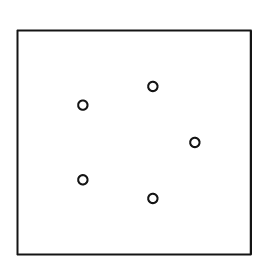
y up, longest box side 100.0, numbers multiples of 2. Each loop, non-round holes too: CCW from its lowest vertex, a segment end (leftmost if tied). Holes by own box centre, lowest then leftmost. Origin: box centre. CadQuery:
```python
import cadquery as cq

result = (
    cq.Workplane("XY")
    .moveTo(-50.0, -48.0)
    .lineTo(50.0, -48.0)
    .lineTo(50.0, 48.0)
    .lineTo(-50.0, 48.0)
    .close()
    .moveTo(8.0, -24.0)
    .circle(2.0)
    .moveTo(-22.0, -16.0)
    .circle(2.0)
    .moveTo(26.0, 0.0)
    .circle(2.0)
    .moveTo(-22.0, 16.0)
    .circle(2.0)
    .moveTo(8.0, 24.0)
    .circle(2.0)
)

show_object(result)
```